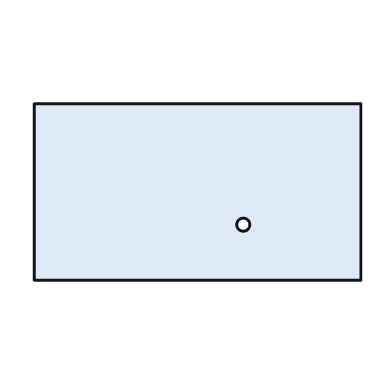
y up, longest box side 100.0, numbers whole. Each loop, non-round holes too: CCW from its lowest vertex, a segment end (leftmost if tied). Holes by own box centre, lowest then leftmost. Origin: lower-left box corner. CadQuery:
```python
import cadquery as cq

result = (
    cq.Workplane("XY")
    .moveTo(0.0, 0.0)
    .lineTo(100.0, 0.0)
    .lineTo(100.0, 54.0)
    .lineTo(0.0, 54.0)
    .close()
    .moveTo(64.0, 17.0)
    .circle(2.0)
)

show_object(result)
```